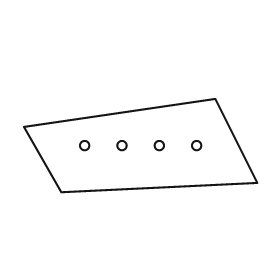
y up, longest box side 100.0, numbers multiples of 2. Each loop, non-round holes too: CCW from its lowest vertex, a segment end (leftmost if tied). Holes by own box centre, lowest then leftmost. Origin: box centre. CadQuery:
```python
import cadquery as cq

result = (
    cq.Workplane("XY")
    .moveTo(-34.0, -20.0)
    .lineTo(50.0, -16.0)
    .lineTo(32.0, 20.0)
    .lineTo(-50.0, 8.0)
    .close()
    .moveTo(-24.0, 0.0)
    .circle(2.0)
    .moveTo(-8.0, 0.0)
    .circle(2.0)
    .moveTo(8.0, 0.0)
    .circle(2.0)
    .moveTo(24.0, 0.0)
    .circle(2.0)
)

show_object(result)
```